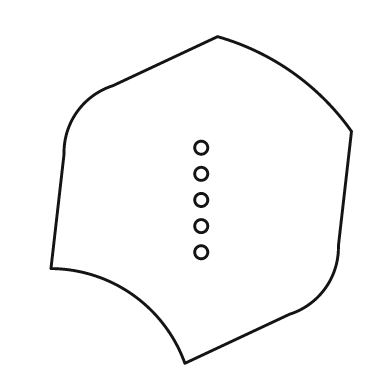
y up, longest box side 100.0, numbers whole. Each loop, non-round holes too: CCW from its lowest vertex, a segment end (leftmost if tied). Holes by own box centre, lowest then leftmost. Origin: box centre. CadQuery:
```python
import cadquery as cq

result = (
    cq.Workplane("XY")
    .moveTo(-5.0, -50.0)
    .lineTo(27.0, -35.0)
    .threePointArc((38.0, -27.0), (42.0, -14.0))
    .lineTo(46.0, 21.0)
    .threePointArc((28.0, 39.0), (5.0, 50.0))
    .lineTo(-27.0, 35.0)
    .threePointArc((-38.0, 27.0), (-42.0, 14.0))
    .lineTo(-46.0, -21.0)
    .threePointArc((-21.0, -29.0), (-5.0, -50.0))
    .close()
    .moveTo(0.0, -16.0)
    .circle(2.0)
    .moveTo(0.0, -8.0)
    .circle(2.0)
    .moveTo(0.0, 0.0)
    .circle(2.0)
    .moveTo(0.0, 8.0)
    .circle(2.0)
    .moveTo(0.0, 16.0)
    .circle(2.0)
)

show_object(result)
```